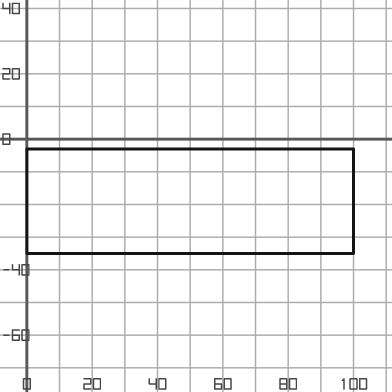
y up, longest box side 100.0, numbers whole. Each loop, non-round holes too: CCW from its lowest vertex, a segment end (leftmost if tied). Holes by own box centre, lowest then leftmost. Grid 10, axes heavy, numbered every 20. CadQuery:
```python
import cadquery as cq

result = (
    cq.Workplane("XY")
    .moveTo(0.0, -35.0)
    .lineTo(100.0, -35.0)
    .lineTo(100.0, -3.0)
    .lineTo(0.0, -3.0)
    .close()
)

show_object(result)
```